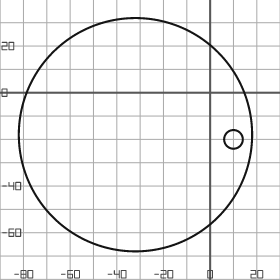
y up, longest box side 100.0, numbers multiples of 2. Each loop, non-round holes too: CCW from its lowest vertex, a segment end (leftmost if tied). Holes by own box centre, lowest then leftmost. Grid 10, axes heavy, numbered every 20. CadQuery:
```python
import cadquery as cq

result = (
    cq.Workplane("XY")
    .moveTo(-32.0, -18.0)
    .circle(50.0)
    .moveTo(10.0, -20.0)
    .circle(4.0)
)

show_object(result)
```